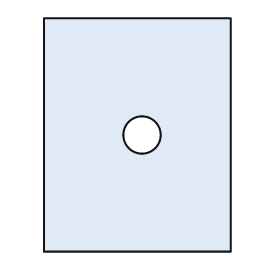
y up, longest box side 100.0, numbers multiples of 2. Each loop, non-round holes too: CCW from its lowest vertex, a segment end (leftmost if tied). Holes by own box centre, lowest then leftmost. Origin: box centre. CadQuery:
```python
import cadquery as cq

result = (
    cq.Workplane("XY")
    .moveTo(-40.0, -50.0)
    .lineTo(40.0, -50.0)
    .lineTo(40.0, 50.0)
    .lineTo(-40.0, 50.0)
    .close()
    .moveTo(2.0, 0.0)
    .circle(8.0)
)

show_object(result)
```